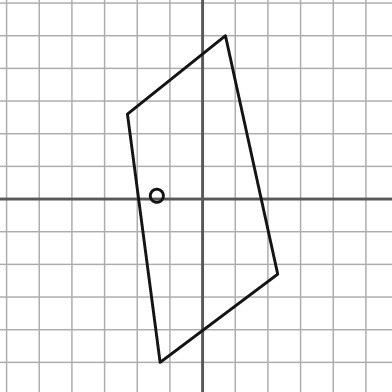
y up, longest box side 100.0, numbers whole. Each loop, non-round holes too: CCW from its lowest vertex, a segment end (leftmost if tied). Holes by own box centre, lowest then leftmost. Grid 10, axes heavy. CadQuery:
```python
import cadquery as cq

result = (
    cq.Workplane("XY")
    .moveTo(-13.0, -50.0)
    .lineTo(23.0, -23.0)
    .lineTo(7.0, 50.0)
    .lineTo(-23.0, 26.0)
    .close()
    .moveTo(-14.0, 1.0)
    .circle(2.0)
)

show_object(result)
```